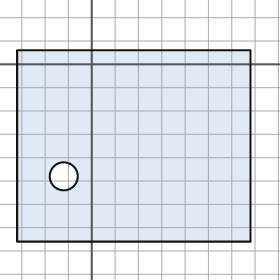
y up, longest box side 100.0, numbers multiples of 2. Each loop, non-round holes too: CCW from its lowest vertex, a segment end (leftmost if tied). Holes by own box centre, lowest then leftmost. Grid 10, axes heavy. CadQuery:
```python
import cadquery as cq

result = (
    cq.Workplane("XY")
    .moveTo(-32.0, -76.0)
    .lineTo(68.0, -76.0)
    .lineTo(68.0, 6.0)
    .lineTo(-32.0, 6.0)
    .close()
    .moveTo(-12.0, -48.0)
    .circle(6.0)
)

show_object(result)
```